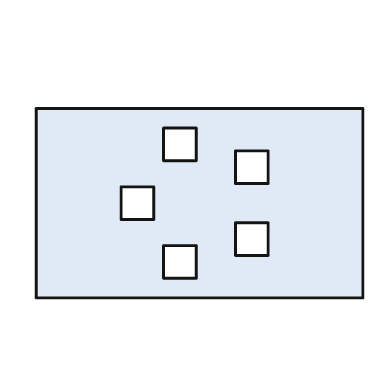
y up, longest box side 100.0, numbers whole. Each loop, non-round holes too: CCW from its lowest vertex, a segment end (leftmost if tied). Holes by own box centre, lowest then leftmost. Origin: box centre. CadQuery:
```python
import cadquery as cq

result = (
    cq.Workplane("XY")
    .moveTo(-50.0, -29.0)
    .lineTo(50.0, -29.0)
    .lineTo(50.0, 29.0)
    .lineTo(-50.0, 29.0)
    .close()
    .moveTo(-11.0, -23.0)
    .lineTo(-1.0, -23.0)
    .lineTo(-1.0, -13.0)
    .lineTo(-11.0, -13.0)
    .close()
    .moveTo(11.0, -16.0)
    .lineTo(21.0, -16.0)
    .lineTo(21.0, -6.0)
    .lineTo(11.0, -6.0)
    .close()
    .moveTo(-24.0, -5.0)
    .lineTo(-14.0, -5.0)
    .lineTo(-14.0, 5.0)
    .lineTo(-24.0, 5.0)
    .close()
    .moveTo(11.0, 6.0)
    .lineTo(21.0, 6.0)
    .lineTo(21.0, 16.0)
    .lineTo(11.0, 16.0)
    .close()
    .moveTo(-11.0, 13.0)
    .lineTo(-1.0, 13.0)
    .lineTo(-1.0, 23.0)
    .lineTo(-11.0, 23.0)
    .close()
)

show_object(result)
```